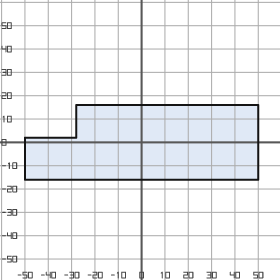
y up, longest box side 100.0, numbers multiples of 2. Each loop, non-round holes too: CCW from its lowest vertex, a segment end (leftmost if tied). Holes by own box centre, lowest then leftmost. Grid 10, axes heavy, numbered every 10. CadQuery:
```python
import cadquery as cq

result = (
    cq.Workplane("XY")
    .moveTo(-50.0, -16.0)
    .lineTo(50.0, -16.0)
    .lineTo(50.0, 16.0)
    .lineTo(-28.0, 16.0)
    .lineTo(-28.0, 2.0)
    .lineTo(-50.0, 2.0)
    .close()
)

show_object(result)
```